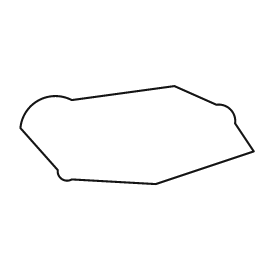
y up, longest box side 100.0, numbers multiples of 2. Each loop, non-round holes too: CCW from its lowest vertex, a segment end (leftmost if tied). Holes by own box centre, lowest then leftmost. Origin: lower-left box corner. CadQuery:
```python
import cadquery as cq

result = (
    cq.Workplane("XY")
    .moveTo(58.0, 0.0)
    .lineTo(100.0, 14.0)
    .lineTo(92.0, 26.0)
    .threePointArc((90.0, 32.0), (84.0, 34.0))
    .lineTo(66.0, 42.0)
    .lineTo(22.0, 36.0)
    .threePointArc((8.0, 36.0), (0.0, 24.0))
    .lineTo(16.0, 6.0)
    .threePointArc((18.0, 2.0), (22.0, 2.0))
    .close()
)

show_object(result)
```